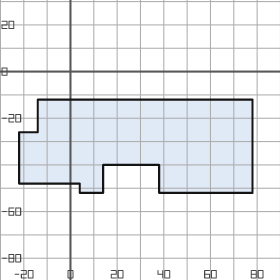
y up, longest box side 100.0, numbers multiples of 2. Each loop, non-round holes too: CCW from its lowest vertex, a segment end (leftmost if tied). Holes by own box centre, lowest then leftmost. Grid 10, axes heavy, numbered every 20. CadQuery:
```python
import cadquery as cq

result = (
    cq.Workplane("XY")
    .moveTo(4.0, -52.0)
    .lineTo(14.0, -52.0)
    .lineTo(14.0, -40.0)
    .lineTo(38.0, -40.0)
    .lineTo(38.0, -52.0)
    .lineTo(78.0, -52.0)
    .lineTo(78.0, -12.0)
    .lineTo(-14.0, -12.0)
    .lineTo(-14.0, -26.0)
    .lineTo(-22.0, -26.0)
    .lineTo(-22.0, -48.0)
    .lineTo(4.0, -48.0)
    .close()
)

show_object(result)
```